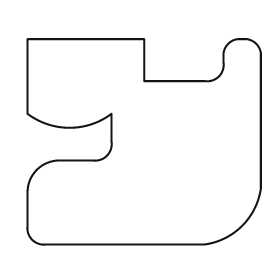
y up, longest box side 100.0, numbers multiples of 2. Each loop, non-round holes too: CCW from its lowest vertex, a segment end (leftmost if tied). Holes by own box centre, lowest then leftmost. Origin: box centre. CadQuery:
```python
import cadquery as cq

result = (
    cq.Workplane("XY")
    .moveTo(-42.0, -44.0)
    .lineTo(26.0, -44.0)
    .threePointArc((42.0, -36.0), (50.0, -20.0))
    .lineTo(50.0, 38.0)
    .threePointArc((48.0, 42.0), (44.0, 44.0))
    .lineTo(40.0, 44.0)
    .threePointArc((36.0, 42.0), (34.0, 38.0))
    .lineTo(34.0, 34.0)
    .threePointArc((32.0, 28.0), (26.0, 26.0))
    .lineTo(0.0, 26.0)
    .lineTo(0.0, 44.0)
    .lineTo(-50.0, 44.0)
    .lineTo(-50.0, 12.0)
    .threePointArc((-32.0, 6.0), (-14.0, 12.0))
    .lineTo(-14.0, 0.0)
    .threePointArc((-16.0, -6.0), (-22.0, -8.0))
    .lineTo(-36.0, -8.0)
    .threePointArc((-46.0, -12.0), (-50.0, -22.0))
    .lineTo(-50.0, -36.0)
    .threePointArc((-48.0, -42.0), (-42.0, -44.0))
    .close()
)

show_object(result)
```